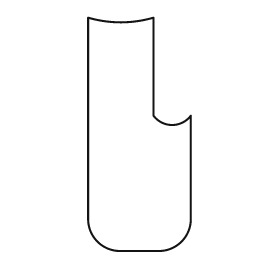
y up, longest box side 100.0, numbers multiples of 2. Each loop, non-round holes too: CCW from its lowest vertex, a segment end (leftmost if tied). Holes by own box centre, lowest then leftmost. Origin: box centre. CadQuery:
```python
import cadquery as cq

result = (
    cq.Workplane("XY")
    .moveTo(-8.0, -50.0)
    .lineTo(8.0, -50.0)
    .threePointArc((18.0, -46.0), (22.0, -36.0))
    .lineTo(22.0, 8.0)
    .threePointArc((14.0, 4.0), (6.0, 8.0))
    .lineTo(6.0, 50.0)
    .threePointArc((-8.0, 48.0), (-22.0, 50.0))
    .lineTo(-22.0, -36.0)
    .threePointArc((-18.0, -46.0), (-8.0, -50.0))
    .close()
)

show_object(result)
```